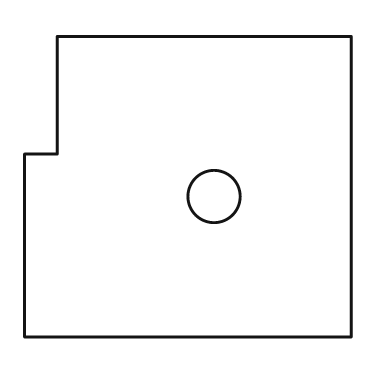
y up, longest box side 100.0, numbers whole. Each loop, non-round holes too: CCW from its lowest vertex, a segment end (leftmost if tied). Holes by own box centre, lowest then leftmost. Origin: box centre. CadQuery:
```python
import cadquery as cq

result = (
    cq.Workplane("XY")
    .moveTo(-50.0, -46.0)
    .lineTo(50.0, -46.0)
    .lineTo(50.0, 46.0)
    .lineTo(-40.0, 46.0)
    .lineTo(-40.0, 10.0)
    .lineTo(-50.0, 10.0)
    .close()
    .moveTo(8.0, -3.0)
    .circle(8.0)
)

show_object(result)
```